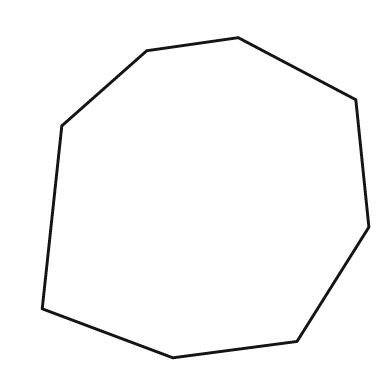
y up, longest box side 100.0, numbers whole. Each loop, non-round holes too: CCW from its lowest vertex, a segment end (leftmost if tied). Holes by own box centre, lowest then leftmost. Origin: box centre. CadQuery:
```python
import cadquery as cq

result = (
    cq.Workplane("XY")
    .moveTo(-10.0, -49.0)
    .lineTo(28.0, -44.0)
    .lineTo(50.0, -9.0)
    .lineTo(46.0, 30.0)
    .lineTo(10.0, 49.0)
    .lineTo(-18.0, 45.0)
    .lineTo(-44.0, 22.0)
    .lineTo(-50.0, -34.0)
    .close()
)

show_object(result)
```